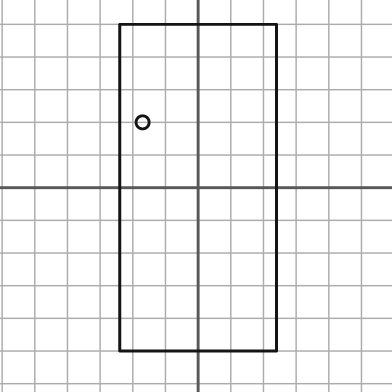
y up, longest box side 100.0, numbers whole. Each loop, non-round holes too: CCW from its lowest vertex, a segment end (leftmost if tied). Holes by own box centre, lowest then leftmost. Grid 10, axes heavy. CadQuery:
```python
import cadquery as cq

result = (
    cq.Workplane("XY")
    .moveTo(-24.0, -50.0)
    .lineTo(24.0, -50.0)
    .lineTo(24.0, 50.0)
    .lineTo(-24.0, 50.0)
    .close()
    .moveTo(-17.0, 20.0)
    .circle(2.0)
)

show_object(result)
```